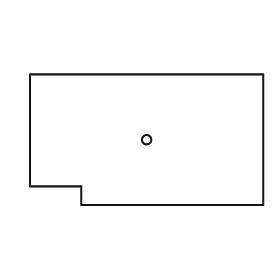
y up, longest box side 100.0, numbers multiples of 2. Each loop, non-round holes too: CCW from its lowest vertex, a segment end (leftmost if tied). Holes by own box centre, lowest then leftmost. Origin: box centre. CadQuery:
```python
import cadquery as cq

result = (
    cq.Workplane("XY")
    .moveTo(-28.0, -28.0)
    .lineTo(50.0, -28.0)
    .lineTo(50.0, 28.0)
    .lineTo(-50.0, 28.0)
    .lineTo(-50.0, -20.0)
    .lineTo(-28.0, -20.0)
    .close()
    .moveTo(0.0, 0.0)
    .circle(2.0)
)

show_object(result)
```